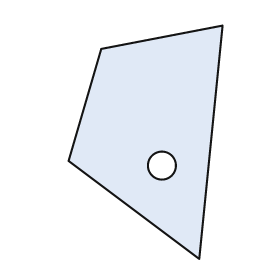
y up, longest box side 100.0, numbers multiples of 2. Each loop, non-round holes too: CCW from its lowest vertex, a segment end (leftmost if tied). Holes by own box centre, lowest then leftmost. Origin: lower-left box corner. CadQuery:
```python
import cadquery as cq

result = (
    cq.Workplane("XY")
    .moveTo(56.0, 0.0)
    .lineTo(66.0, 100.0)
    .lineTo(14.0, 90.0)
    .lineTo(0.0, 42.0)
    .close()
    .moveTo(40.0, 40.0)
    .circle(6.0)
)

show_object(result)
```